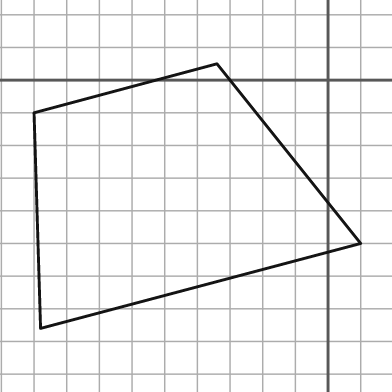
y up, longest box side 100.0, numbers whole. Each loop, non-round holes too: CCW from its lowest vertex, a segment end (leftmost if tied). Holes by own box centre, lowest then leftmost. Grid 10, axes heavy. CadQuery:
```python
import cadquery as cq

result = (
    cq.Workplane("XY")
    .moveTo(-88.0, -76.0)
    .lineTo(10.0, -50.0)
    .lineTo(-34.0, 5.0)
    .lineTo(-90.0, -10.0)
    .close()
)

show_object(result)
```